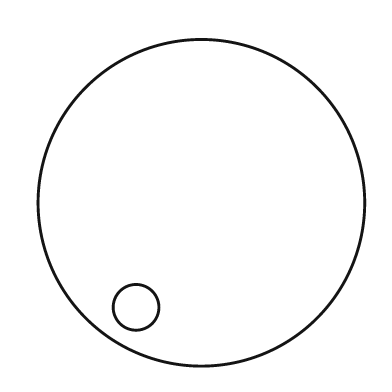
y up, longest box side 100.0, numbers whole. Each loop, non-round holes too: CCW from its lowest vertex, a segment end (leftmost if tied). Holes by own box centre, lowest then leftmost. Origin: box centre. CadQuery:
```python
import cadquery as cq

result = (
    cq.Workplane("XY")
    .moveTo(0.0, 0.0)
    .circle(50.0)
    .moveTo(-20.0, -32.0)
    .circle(7.0)
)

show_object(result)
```